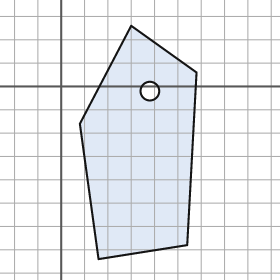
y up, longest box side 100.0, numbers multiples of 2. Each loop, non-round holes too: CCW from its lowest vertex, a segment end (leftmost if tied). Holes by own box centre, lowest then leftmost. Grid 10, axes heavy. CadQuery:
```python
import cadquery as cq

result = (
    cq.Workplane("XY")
    .moveTo(16.0, -74.0)
    .lineTo(54.0, -68.0)
    .lineTo(58.0, 6.0)
    .lineTo(30.0, 26.0)
    .lineTo(8.0, -16.0)
    .close()
    .moveTo(38.0, -2.0)
    .circle(4.0)
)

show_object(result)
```